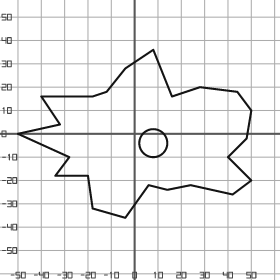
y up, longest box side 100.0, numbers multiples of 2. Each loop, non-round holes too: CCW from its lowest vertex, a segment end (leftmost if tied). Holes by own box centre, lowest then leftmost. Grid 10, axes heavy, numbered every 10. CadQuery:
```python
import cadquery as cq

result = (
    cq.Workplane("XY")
    .moveTo(-4.0, -36.0)
    .lineTo(6.0, -22.0)
    .lineTo(14.0, -24.0)
    .lineTo(24.0, -22.0)
    .lineTo(42.0, -26.0)
    .lineTo(50.0, -20.0)
    .lineTo(40.0, -10.0)
    .lineTo(48.0, -2.0)
    .lineTo(50.0, 10.0)
    .lineTo(44.0, 18.0)
    .lineTo(28.0, 20.0)
    .lineTo(16.0, 16.0)
    .lineTo(8.0, 36.0)
    .lineTo(-4.0, 28.0)
    .lineTo(-12.0, 18.0)
    .lineTo(-18.0, 16.0)
    .lineTo(-40.0, 16.0)
    .lineTo(-32.0, 4.0)
    .lineTo(-50.0, 0.0)
    .lineTo(-28.0, -10.0)
    .lineTo(-34.0, -18.0)
    .lineTo(-20.0, -18.0)
    .lineTo(-18.0, -32.0)
    .close()
    .moveTo(8.0, -4.0)
    .circle(6.0)
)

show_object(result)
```